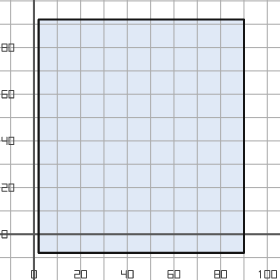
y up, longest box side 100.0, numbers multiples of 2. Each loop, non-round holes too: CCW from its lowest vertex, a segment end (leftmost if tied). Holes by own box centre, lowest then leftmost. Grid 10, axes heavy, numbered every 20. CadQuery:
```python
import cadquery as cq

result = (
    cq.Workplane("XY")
    .moveTo(2.0, -8.0)
    .lineTo(90.0, -8.0)
    .lineTo(90.0, 92.0)
    .lineTo(2.0, 92.0)
    .close()
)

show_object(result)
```